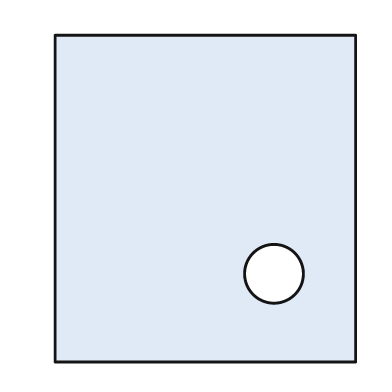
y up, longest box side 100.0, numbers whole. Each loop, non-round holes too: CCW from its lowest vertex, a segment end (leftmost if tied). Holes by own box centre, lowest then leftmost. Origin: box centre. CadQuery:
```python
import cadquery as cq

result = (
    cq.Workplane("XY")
    .moveTo(-46.0, -50.0)
    .lineTo(46.0, -50.0)
    .lineTo(46.0, 50.0)
    .lineTo(-46.0, 50.0)
    .close()
    .moveTo(21.0, -23.0)
    .circle(9.0)
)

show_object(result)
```